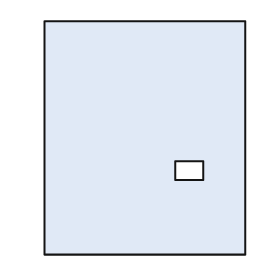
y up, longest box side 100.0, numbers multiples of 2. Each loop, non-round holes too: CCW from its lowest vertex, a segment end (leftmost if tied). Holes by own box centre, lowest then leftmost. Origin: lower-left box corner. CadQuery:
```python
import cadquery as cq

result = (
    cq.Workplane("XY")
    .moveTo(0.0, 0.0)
    .lineTo(86.0, 0.0)
    .lineTo(86.0, 100.0)
    .lineTo(0.0, 100.0)
    .close()
    .moveTo(56.0, 32.0)
    .lineTo(68.0, 32.0)
    .lineTo(68.0, 40.0)
    .lineTo(56.0, 40.0)
    .close()
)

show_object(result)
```